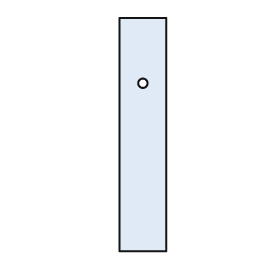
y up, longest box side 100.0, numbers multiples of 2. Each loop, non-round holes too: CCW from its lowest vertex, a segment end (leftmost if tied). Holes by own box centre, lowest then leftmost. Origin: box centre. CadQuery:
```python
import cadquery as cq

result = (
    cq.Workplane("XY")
    .moveTo(-10.0, -50.0)
    .lineTo(10.0, -50.0)
    .lineTo(10.0, 50.0)
    .lineTo(-10.0, 50.0)
    .close()
    .moveTo(0.0, 22.0)
    .circle(2.0)
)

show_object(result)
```